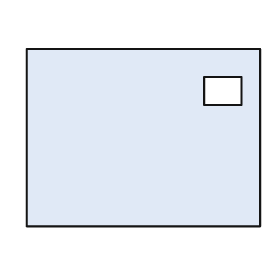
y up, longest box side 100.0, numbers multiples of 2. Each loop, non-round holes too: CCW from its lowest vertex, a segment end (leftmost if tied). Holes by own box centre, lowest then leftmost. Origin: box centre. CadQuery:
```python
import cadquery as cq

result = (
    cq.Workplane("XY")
    .moveTo(-50.0, -38.0)
    .lineTo(50.0, -38.0)
    .lineTo(50.0, 38.0)
    .lineTo(-50.0, 38.0)
    .close()
    .moveTo(26.0, 14.0)
    .lineTo(42.0, 14.0)
    .lineTo(42.0, 26.0)
    .lineTo(26.0, 26.0)
    .close()
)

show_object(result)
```